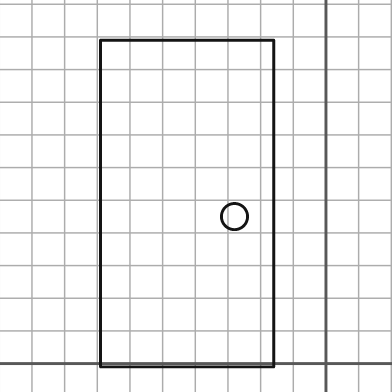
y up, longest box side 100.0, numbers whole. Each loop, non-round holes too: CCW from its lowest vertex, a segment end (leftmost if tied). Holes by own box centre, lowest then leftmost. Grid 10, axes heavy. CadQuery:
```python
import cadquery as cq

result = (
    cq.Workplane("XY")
    .moveTo(-69.0, -1.0)
    .lineTo(-16.0, -1.0)
    .lineTo(-16.0, 99.0)
    .lineTo(-69.0, 99.0)
    .close()
    .moveTo(-28.0, 45.0)
    .circle(4.0)
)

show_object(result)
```